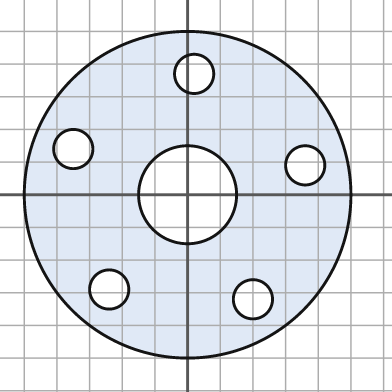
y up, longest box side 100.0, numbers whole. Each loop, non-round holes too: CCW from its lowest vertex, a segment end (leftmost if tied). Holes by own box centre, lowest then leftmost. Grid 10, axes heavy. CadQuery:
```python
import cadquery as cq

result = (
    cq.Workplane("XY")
    .moveTo(0.0, 0.0)
    .circle(50.0)
    .moveTo(20.0, -32.0)
    .circle(6.0)
    .moveTo(-24.0, -29.0)
    .circle(6.0)
    .moveTo(0.0, 0.0)
    .circle(15.0)
    .moveTo(36.0, 9.0)
    .circle(6.0)
    .moveTo(-35.0, 14.0)
    .circle(6.0)
    .moveTo(2.0, 37.0)
    .circle(6.0)
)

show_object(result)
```